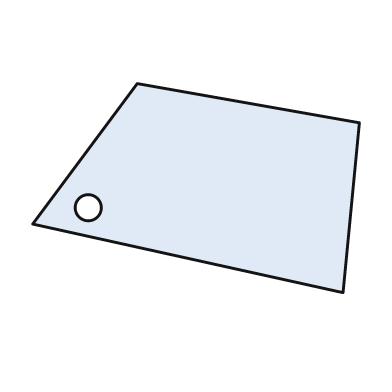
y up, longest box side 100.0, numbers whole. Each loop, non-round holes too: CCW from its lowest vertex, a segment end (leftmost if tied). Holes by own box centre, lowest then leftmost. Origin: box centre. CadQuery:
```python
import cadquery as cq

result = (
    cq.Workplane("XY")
    .moveTo(45.0, -32.0)
    .lineTo(50.0, 20.0)
    .lineTo(-18.0, 32.0)
    .lineTo(-50.0, -11.0)
    .close()
    .moveTo(-33.0, -6.0)
    .circle(4.0)
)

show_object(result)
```